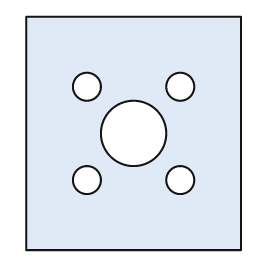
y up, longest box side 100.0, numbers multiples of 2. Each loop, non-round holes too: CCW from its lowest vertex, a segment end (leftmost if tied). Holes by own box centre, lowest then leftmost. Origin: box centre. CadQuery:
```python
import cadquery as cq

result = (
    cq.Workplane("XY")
    .moveTo(-46.0, -50.0)
    .lineTo(46.0, -50.0)
    .lineTo(46.0, 50.0)
    .lineTo(-46.0, 50.0)
    .close()
    .moveTo(-20.0, -20.0)
    .circle(6.0)
    .moveTo(20.0, -20.0)
    .circle(6.0)
    .moveTo(0.0, 0.0)
    .circle(14.0)
    .moveTo(-20.0, 20.0)
    .circle(6.0)
    .moveTo(20.0, 20.0)
    .circle(6.0)
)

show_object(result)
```